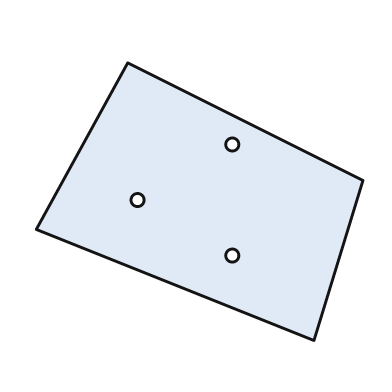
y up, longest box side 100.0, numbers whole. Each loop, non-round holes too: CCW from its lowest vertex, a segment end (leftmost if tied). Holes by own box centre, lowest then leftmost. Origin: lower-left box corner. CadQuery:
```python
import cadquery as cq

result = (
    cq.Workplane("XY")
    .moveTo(85.0, 0.0)
    .lineTo(100.0, 49.0)
    .lineTo(28.0, 85.0)
    .lineTo(0.0, 34.0)
    .close()
    .moveTo(60.0, 26.0)
    .circle(2.0)
    .moveTo(31.0, 43.0)
    .circle(2.0)
    .moveTo(60.0, 60.0)
    .circle(2.0)
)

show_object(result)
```